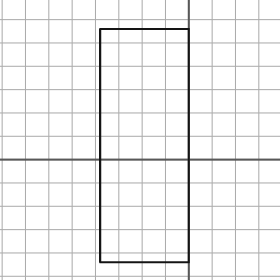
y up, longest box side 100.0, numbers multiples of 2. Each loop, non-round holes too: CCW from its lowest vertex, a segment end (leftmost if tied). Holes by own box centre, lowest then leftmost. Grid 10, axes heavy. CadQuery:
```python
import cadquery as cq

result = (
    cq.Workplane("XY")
    .moveTo(-38.0, -44.0)
    .lineTo(0.0, -44.0)
    .lineTo(0.0, 56.0)
    .lineTo(-38.0, 56.0)
    .close()
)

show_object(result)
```